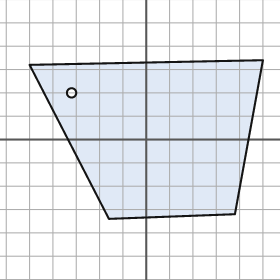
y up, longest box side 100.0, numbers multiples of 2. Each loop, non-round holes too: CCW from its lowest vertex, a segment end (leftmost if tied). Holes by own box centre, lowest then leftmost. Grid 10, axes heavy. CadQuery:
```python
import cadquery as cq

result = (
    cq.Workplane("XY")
    .moveTo(-16.0, -34.0)
    .lineTo(38.0, -32.0)
    .lineTo(50.0, 34.0)
    .lineTo(-50.0, 32.0)
    .close()
    .moveTo(-32.0, 20.0)
    .circle(2.0)
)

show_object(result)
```